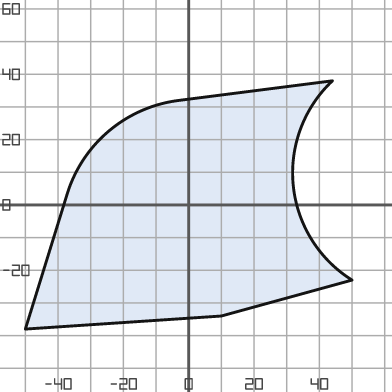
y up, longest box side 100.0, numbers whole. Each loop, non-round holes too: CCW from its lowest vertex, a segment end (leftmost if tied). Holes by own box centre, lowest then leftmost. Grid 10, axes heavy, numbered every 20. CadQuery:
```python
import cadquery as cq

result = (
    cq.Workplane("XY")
    .moveTo(-50.0, -38.0)
    .lineTo(10.0, -34.0)
    .lineTo(50.0, -23.0)
    .threePointArc((32.0, 6.0), (44.0, 38.0))
    .lineTo(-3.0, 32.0)
    .threePointArc((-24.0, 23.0), (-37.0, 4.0))
    .close()
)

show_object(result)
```